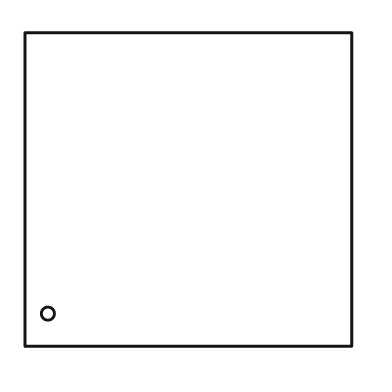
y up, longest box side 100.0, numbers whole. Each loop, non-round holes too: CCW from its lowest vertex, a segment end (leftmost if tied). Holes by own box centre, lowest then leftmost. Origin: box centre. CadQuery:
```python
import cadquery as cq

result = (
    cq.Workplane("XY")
    .moveTo(-50.0, -48.0)
    .lineTo(50.0, -48.0)
    .lineTo(50.0, 48.0)
    .lineTo(-50.0, 48.0)
    .close()
    .moveTo(-43.0, -38.0)
    .circle(2.0)
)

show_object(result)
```